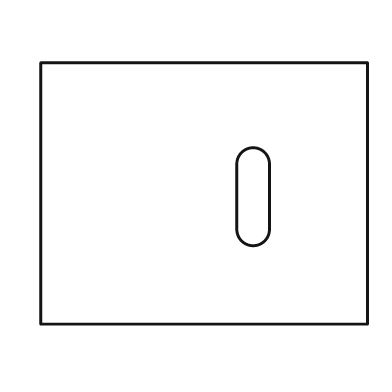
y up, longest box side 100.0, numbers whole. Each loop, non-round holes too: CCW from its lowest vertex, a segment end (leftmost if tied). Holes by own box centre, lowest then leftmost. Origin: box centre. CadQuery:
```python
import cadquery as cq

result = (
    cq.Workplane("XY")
    .moveTo(-50.0, -40.0)
    .lineTo(50.0, -40.0)
    .lineTo(50.0, 40.0)
    .lineTo(-50.0, 40.0)
    .close()
    .moveTo(10.0, -11.0)
    .threePointArc((15.0, -16.0), (20.0, -11.0))
    .lineTo(20.0, 9.0)
    .threePointArc((15.0, 14.0), (10.0, 9.0))
    .close()
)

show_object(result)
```